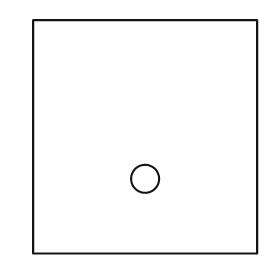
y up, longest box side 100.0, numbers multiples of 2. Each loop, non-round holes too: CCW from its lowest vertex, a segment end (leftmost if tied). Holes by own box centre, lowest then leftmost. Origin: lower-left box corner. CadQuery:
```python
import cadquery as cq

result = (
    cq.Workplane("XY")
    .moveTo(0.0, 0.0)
    .lineTo(96.0, 0.0)
    .lineTo(96.0, 100.0)
    .lineTo(0.0, 100.0)
    .close()
    .moveTo(48.0, 32.0)
    .circle(6.0)
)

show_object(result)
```